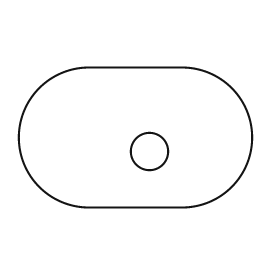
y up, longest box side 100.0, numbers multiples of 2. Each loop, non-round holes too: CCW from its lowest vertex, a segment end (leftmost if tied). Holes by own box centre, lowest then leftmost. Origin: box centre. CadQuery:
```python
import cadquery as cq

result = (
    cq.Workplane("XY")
    .moveTo(-20.0, -30.0)
    .lineTo(20.0, -30.0)
    .threePointArc((50.0, 0.0), (20.0, 30.0))
    .lineTo(-20.0, 30.0)
    .threePointArc((-50.0, 0.0), (-20.0, -30.0))
    .close()
    .moveTo(6.0, -6.0)
    .circle(8.0)
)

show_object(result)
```